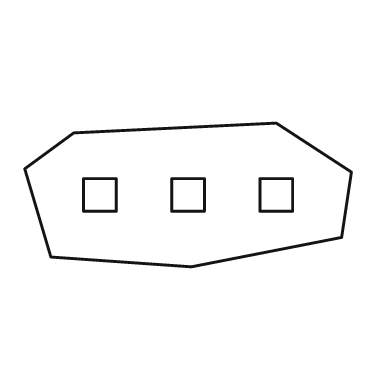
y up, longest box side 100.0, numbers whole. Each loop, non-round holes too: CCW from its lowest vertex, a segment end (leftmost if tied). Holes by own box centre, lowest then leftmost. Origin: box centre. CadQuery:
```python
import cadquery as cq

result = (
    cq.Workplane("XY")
    .moveTo(1.0, -22.0)
    .lineTo(47.0, -13.0)
    .lineTo(50.0, 7.0)
    .lineTo(27.0, 22.0)
    .lineTo(-35.0, 19.0)
    .lineTo(-50.0, 8.0)
    .lineTo(-42.0, -19.0)
    .close()
    .moveTo(-32.0, -5.0)
    .lineTo(-22.0, -5.0)
    .lineTo(-22.0, 5.0)
    .lineTo(-32.0, 5.0)
    .close()
    .moveTo(-5.0, -5.0)
    .lineTo(5.0, -5.0)
    .lineTo(5.0, 5.0)
    .lineTo(-5.0, 5.0)
    .close()
    .moveTo(22.0, -5.0)
    .lineTo(32.0, -5.0)
    .lineTo(32.0, 5.0)
    .lineTo(22.0, 5.0)
    .close()
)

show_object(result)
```